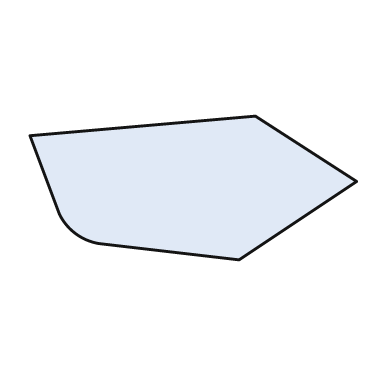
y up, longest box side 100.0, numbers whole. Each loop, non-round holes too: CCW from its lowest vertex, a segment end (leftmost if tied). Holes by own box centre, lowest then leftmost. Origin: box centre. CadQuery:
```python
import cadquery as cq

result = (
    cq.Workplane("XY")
    .moveTo(14.0, -22.0)
    .lineTo(50.0, 2.0)
    .lineTo(19.0, 22.0)
    .lineTo(-50.0, 16.0)
    .lineTo(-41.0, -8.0)
    .threePointArc((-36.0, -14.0), (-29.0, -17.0))
    .close()
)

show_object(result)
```